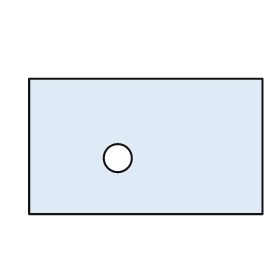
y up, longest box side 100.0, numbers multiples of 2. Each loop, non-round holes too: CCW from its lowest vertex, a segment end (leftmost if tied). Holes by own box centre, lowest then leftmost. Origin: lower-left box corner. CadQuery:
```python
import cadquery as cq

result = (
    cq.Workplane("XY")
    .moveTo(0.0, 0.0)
    .lineTo(100.0, 0.0)
    .lineTo(100.0, 58.0)
    .lineTo(0.0, 58.0)
    .close()
    .moveTo(38.0, 24.0)
    .circle(6.0)
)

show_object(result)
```